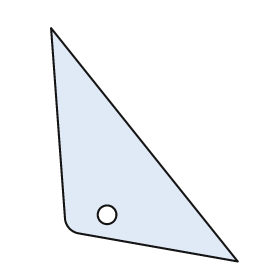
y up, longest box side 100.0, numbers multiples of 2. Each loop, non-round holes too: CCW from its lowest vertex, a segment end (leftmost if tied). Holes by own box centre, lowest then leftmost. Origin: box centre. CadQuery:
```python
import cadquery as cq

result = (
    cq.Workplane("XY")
    .moveTo(40.0, -50.0)
    .lineTo(-40.0, 50.0)
    .lineTo(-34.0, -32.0)
    .threePointArc((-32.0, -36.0), (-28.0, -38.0))
    .close()
    .moveTo(-16.0, -30.0)
    .circle(4.0)
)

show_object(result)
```